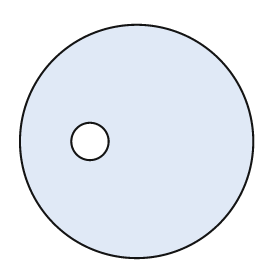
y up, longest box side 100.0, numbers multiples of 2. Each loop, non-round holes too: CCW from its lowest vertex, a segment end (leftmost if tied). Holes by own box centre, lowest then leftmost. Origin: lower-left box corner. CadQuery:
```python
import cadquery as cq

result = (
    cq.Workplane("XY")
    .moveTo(50.0, 50.0)
    .circle(50.0)
    .moveTo(30.0, 50.0)
    .circle(8.0)
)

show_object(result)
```